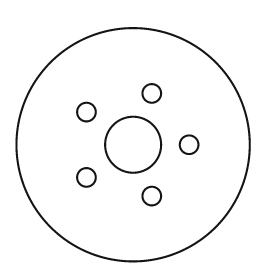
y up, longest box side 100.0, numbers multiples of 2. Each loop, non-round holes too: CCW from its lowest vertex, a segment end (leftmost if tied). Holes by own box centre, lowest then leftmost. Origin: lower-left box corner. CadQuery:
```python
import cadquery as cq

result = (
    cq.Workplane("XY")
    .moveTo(50.0, 50.0)
    .circle(50.0)
    .moveTo(58.0, 28.0)
    .circle(4.0)
    .moveTo(30.0, 36.0)
    .circle(4.0)
    .moveTo(50.0, 50.0)
    .circle(12.0)
    .moveTo(74.0, 50.0)
    .circle(4.0)
    .moveTo(30.0, 64.0)
    .circle(4.0)
    .moveTo(58.0, 72.0)
    .circle(4.0)
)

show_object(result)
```